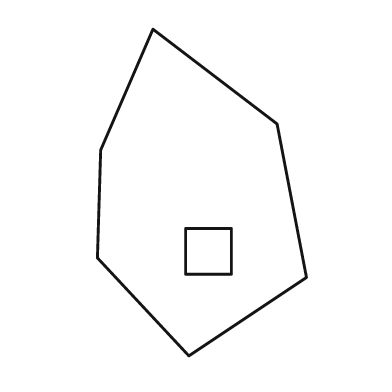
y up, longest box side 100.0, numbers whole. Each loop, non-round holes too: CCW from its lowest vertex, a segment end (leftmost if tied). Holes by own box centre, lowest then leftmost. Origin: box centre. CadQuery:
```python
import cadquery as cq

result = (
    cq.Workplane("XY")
    .moveTo(-4.0, -50.0)
    .lineTo(32.0, -26.0)
    .lineTo(23.0, 21.0)
    .lineTo(-15.0, 50.0)
    .lineTo(-31.0, 13.0)
    .lineTo(-32.0, -20.0)
    .close()
    .moveTo(-5.0, -25.0)
    .lineTo(9.0, -25.0)
    .lineTo(9.0, -11.0)
    .lineTo(-5.0, -11.0)
    .close()
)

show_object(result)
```